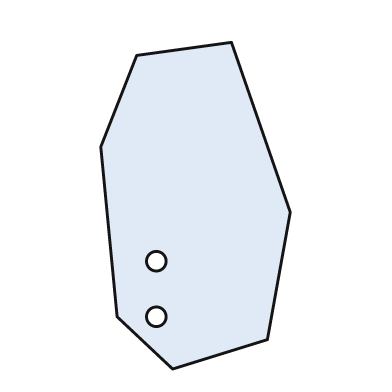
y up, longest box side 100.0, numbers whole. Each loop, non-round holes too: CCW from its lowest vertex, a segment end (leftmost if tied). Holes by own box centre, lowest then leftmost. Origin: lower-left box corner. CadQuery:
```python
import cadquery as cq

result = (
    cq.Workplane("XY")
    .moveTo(22.0, 0.0)
    .lineTo(51.0, 9.0)
    .lineTo(58.0, 48.0)
    .lineTo(40.0, 100.0)
    .lineTo(11.0, 96.0)
    .lineTo(0.0, 68.0)
    .lineTo(5.0, 16.0)
    .close()
    .moveTo(17.0, 16.0)
    .circle(3.0)
    .moveTo(17.0, 33.0)
    .circle(3.0)
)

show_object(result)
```